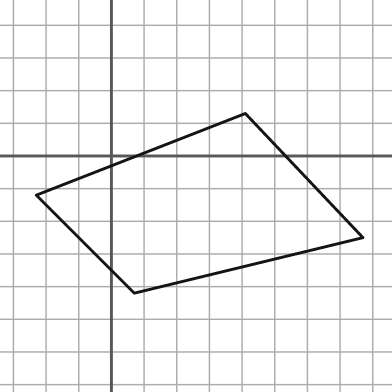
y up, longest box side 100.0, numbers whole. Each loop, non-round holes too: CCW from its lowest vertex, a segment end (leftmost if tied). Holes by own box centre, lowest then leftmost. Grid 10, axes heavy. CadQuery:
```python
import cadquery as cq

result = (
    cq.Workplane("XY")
    .moveTo(7.0, -42.0)
    .lineTo(77.0, -25.0)
    .lineTo(41.0, 13.0)
    .lineTo(-23.0, -12.0)
    .close()
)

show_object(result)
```